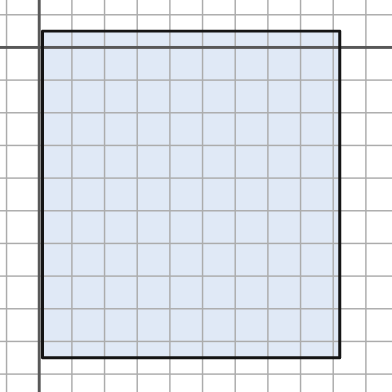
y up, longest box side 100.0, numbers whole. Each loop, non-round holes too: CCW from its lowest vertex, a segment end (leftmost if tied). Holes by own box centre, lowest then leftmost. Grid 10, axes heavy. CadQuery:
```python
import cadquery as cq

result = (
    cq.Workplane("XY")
    .moveTo(1.0, -95.0)
    .lineTo(92.0, -95.0)
    .lineTo(92.0, 5.0)
    .lineTo(1.0, 5.0)
    .close()
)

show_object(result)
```